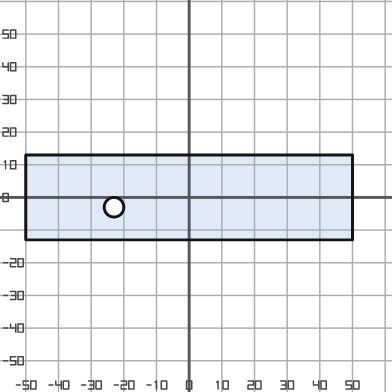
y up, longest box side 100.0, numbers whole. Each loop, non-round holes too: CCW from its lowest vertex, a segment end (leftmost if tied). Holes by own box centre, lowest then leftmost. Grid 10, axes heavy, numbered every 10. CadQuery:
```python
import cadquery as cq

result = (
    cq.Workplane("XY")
    .moveTo(-50.0, -13.0)
    .lineTo(50.0, -13.0)
    .lineTo(50.0, 13.0)
    .lineTo(-50.0, 13.0)
    .close()
    .moveTo(-23.0, -3.0)
    .circle(3.0)
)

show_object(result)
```